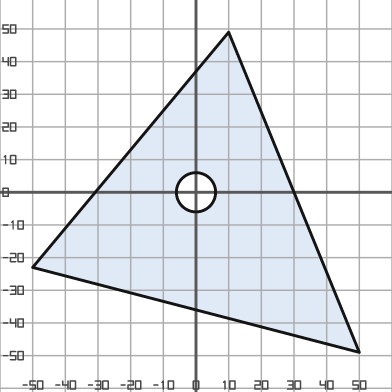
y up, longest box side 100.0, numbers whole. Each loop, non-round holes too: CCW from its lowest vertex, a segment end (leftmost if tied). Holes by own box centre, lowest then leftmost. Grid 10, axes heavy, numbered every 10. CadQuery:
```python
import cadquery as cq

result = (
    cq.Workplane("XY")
    .moveTo(50.0, -49.0)
    .lineTo(10.0, 49.0)
    .lineTo(-50.0, -23.0)
    .close()
    .moveTo(0.0, 0.0)
    .circle(6.0)
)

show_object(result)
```